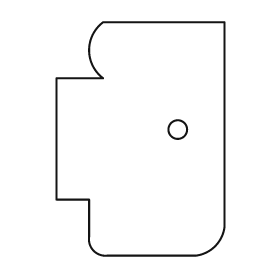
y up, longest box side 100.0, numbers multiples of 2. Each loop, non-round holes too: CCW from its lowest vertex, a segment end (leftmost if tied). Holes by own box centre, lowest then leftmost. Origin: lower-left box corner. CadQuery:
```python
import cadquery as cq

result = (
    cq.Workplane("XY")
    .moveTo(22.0, 0.0)
    .lineTo(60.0, 0.0)
    .threePointArc((68.0, 4.0), (72.0, 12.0))
    .lineTo(72.0, 100.0)
    .lineTo(20.0, 100.0)
    .threePointArc((14.0, 88.0), (20.0, 76.0))
    .lineTo(0.0, 76.0)
    .lineTo(0.0, 24.0)
    .lineTo(14.0, 24.0)
    .lineTo(14.0, 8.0)
    .threePointArc((16.0, 2.0), (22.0, 0.0))
    .close()
    .moveTo(52.0, 54.0)
    .circle(4.0)
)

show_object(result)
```